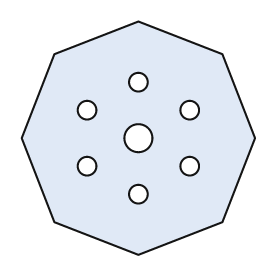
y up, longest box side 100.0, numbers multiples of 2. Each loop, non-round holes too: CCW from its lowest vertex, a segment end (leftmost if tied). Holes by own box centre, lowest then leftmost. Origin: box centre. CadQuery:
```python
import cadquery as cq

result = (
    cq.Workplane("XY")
    .moveTo(0.0, -50.0)
    .lineTo(36.0, -36.0)
    .lineTo(50.0, 0.0)
    .lineTo(36.0, 36.0)
    .lineTo(0.0, 50.0)
    .lineTo(-36.0, 36.0)
    .lineTo(-50.0, 0.0)
    .lineTo(-36.0, -36.0)
    .close()
    .moveTo(0.0, -24.0)
    .circle(4.0)
    .moveTo(-22.0, -12.0)
    .circle(4.0)
    .moveTo(22.0, -12.0)
    .circle(4.0)
    .moveTo(0.0, 0.0)
    .circle(6.0)
    .moveTo(-22.0, 12.0)
    .circle(4.0)
    .moveTo(22.0, 12.0)
    .circle(4.0)
    .moveTo(0.0, 24.0)
    .circle(4.0)
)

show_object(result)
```